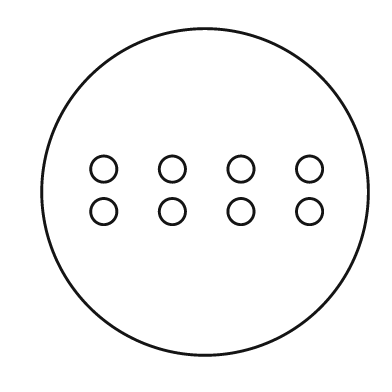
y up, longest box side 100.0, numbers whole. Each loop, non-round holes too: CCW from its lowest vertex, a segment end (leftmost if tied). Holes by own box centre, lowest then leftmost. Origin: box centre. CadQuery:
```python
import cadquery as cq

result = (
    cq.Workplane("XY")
    .moveTo(0.0, 0.0)
    .circle(50.0)
    .moveTo(-31.0, -6.0)
    .circle(4.0)
    .moveTo(-10.0, -6.0)
    .circle(4.0)
    .moveTo(11.0, -6.0)
    .circle(4.0)
    .moveTo(32.0, -6.0)
    .circle(4.0)
    .moveTo(-31.0, 7.0)
    .circle(4.0)
    .moveTo(-10.0, 7.0)
    .circle(4.0)
    .moveTo(11.0, 7.0)
    .circle(4.0)
    .moveTo(32.0, 7.0)
    .circle(4.0)
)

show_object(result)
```